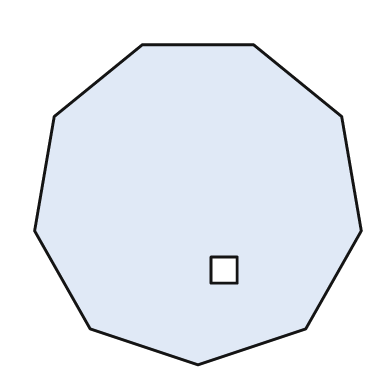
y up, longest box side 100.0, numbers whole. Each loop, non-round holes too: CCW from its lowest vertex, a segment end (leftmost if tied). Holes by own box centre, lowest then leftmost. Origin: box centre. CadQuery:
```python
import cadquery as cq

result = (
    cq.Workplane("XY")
    .moveTo(0.0, -49.0)
    .lineTo(33.0, -38.0)
    .lineTo(50.0, -8.0)
    .lineTo(44.0, 27.0)
    .lineTo(17.0, 49.0)
    .lineTo(-17.0, 49.0)
    .lineTo(-44.0, 27.0)
    .lineTo(-50.0, -8.0)
    .lineTo(-33.0, -38.0)
    .close()
    .moveTo(4.0, -24.0)
    .lineTo(12.0, -24.0)
    .lineTo(12.0, -16.0)
    .lineTo(4.0, -16.0)
    .close()
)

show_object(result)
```